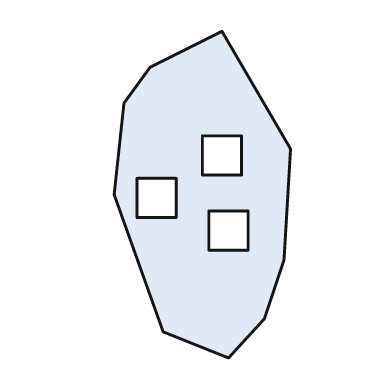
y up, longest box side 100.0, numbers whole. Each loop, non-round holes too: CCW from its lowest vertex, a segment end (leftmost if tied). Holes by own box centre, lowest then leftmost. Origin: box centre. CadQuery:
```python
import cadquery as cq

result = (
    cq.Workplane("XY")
    .moveTo(8.0, -50.0)
    .lineTo(19.0, -38.0)
    .lineTo(25.0, -20.0)
    .lineTo(27.0, 14.0)
    .lineTo(6.0, 50.0)
    .lineTo(-16.0, 39.0)
    .lineTo(-24.0, 28.0)
    .lineTo(-27.0, 0.0)
    .lineTo(-12.0, -42.0)
    .close()
    .moveTo(2.0, -17.0)
    .lineTo(14.0, -17.0)
    .lineTo(14.0, -5.0)
    .lineTo(2.0, -5.0)
    .close()
    .moveTo(-20.0, -7.0)
    .lineTo(-8.0, -7.0)
    .lineTo(-8.0, 5.0)
    .lineTo(-20.0, 5.0)
    .close()
    .moveTo(0.0, 6.0)
    .lineTo(12.0, 6.0)
    .lineTo(12.0, 18.0)
    .lineTo(0.0, 18.0)
    .close()
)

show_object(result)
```